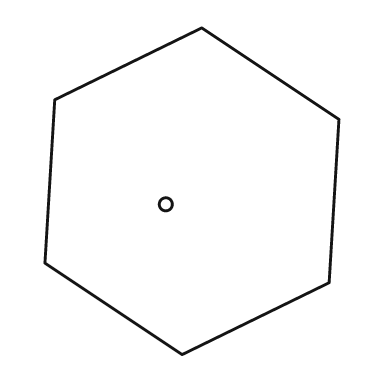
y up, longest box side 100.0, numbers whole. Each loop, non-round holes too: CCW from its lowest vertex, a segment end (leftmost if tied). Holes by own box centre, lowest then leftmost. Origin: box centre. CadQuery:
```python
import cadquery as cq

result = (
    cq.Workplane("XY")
    .moveTo(-3.0, -50.0)
    .lineTo(42.0, -28.0)
    .lineTo(45.0, 22.0)
    .lineTo(3.0, 50.0)
    .lineTo(-42.0, 28.0)
    .lineTo(-45.0, -22.0)
    .close()
    .moveTo(-8.0, -4.0)
    .circle(2.0)
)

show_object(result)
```